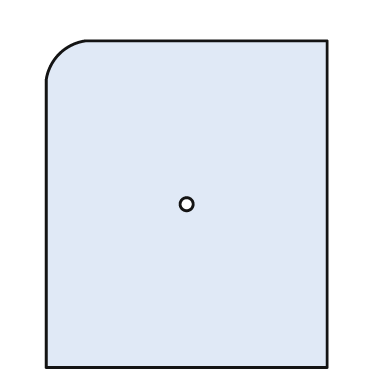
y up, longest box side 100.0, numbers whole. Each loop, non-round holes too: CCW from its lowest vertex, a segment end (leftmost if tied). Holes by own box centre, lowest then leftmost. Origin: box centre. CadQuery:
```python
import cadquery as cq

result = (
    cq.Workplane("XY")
    .moveTo(-43.0, -50.0)
    .lineTo(43.0, -50.0)
    .lineTo(43.0, 50.0)
    .lineTo(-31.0, 50.0)
    .threePointArc((-39.0, 46.0), (-43.0, 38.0))
    .close()
    .moveTo(0.0, 0.0)
    .circle(2.0)
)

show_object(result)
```